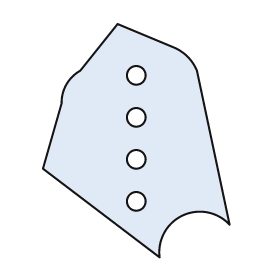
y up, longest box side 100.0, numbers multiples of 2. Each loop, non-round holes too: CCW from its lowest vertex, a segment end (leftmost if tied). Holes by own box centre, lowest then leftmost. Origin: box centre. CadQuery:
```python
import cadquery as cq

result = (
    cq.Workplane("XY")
    .moveTo(10.0, -50.0)
    .threePointArc((20.0, -32.0), (40.0, -36.0))
    .lineTo(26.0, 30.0)
    .threePointArc((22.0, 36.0), (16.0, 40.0))
    .lineTo(-8.0, 50.0)
    .lineTo(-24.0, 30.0)
    .threePointArc((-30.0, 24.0), (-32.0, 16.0))
    .lineTo(-40.0, -12.0)
    .close()
    .moveTo(0.0, -26.0)
    .circle(4.0)
    .moveTo(0.0, -8.0)
    .circle(4.0)
    .moveTo(0.0, 10.0)
    .circle(4.0)
    .moveTo(0.0, 28.0)
    .circle(4.0)
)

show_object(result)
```